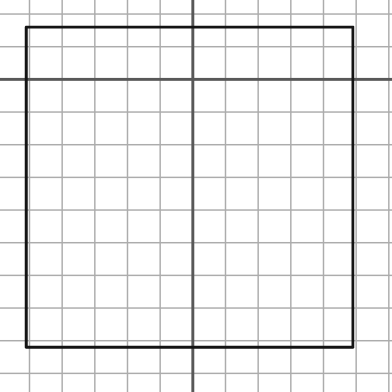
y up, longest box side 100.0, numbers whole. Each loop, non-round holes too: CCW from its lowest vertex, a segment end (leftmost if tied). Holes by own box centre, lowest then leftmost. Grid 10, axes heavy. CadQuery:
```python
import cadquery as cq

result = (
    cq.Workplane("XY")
    .moveTo(-51.0, -82.0)
    .lineTo(49.0, -82.0)
    .lineTo(49.0, 16.0)
    .lineTo(-51.0, 16.0)
    .close()
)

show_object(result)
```